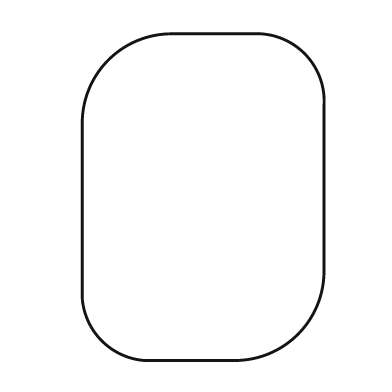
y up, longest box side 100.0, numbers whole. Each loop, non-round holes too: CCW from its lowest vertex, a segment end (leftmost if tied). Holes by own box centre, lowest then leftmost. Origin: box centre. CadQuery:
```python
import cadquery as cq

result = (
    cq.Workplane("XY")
    .moveTo(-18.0, -50.0)
    .lineTo(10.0, -50.0)
    .threePointArc((29.0, -42.0), (37.0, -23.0))
    .lineTo(37.0, 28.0)
    .threePointArc((31.0, 44.0), (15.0, 50.0))
    .lineTo(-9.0, 50.0)
    .threePointArc((-29.0, 42.0), (-37.0, 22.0))
    .lineTo(-37.0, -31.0)
    .threePointArc((-31.0, -44.0), (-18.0, -50.0))
    .close()
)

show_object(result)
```